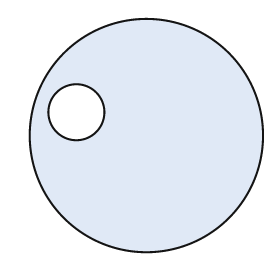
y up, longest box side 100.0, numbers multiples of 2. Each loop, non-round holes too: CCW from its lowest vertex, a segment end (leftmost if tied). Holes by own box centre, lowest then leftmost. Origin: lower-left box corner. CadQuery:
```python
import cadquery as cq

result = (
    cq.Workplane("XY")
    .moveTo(50.0, 50.0)
    .circle(50.0)
    .moveTo(20.0, 60.0)
    .circle(12.0)
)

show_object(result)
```